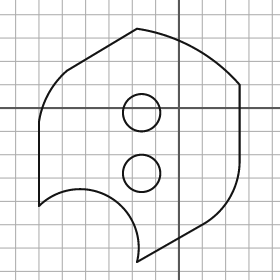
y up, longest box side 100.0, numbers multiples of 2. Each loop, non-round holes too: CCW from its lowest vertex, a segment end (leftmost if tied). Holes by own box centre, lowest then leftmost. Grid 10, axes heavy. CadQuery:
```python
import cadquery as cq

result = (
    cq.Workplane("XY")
    .moveTo(-18.0, -66.0)
    .lineTo(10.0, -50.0)
    .threePointArc((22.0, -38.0), (26.0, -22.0))
    .lineTo(26.0, 10.0)
    .threePointArc((6.0, 26.0), (-18.0, 34.0))
    .lineTo(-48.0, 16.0)
    .threePointArc((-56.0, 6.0), (-60.0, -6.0))
    .lineTo(-60.0, -42.0)
    .threePointArc((-30.0, -38.0), (-18.0, -66.0))
    .close()
    .moveTo(-16.0, -28.0)
    .circle(8.0)
    .moveTo(-16.0, -2.0)
    .circle(8.0)
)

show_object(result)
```